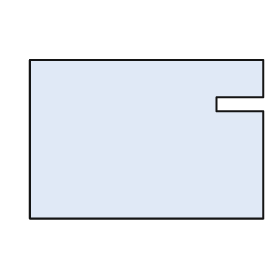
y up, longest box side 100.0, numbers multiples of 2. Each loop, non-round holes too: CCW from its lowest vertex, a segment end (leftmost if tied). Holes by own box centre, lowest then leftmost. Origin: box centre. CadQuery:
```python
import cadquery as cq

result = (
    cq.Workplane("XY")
    .moveTo(-50.0, -34.0)
    .lineTo(50.0, -34.0)
    .lineTo(50.0, 12.0)
    .lineTo(30.0, 12.0)
    .lineTo(30.0, 18.0)
    .lineTo(50.0, 18.0)
    .lineTo(50.0, 34.0)
    .lineTo(-50.0, 34.0)
    .close()
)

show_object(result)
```